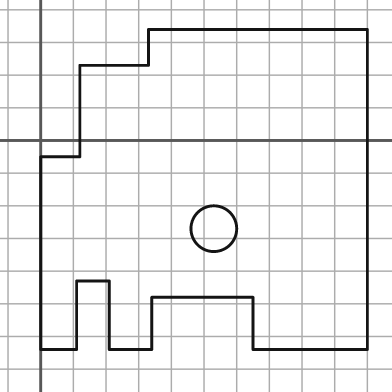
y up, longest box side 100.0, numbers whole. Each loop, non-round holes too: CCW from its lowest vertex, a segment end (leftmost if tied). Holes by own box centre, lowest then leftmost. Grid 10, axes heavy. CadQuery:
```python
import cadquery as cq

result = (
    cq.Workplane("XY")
    .moveTo(0.0, -64.0)
    .lineTo(11.0, -64.0)
    .lineTo(11.0, -43.0)
    .lineTo(21.0, -43.0)
    .lineTo(21.0, -64.0)
    .lineTo(34.0, -64.0)
    .lineTo(34.0, -48.0)
    .lineTo(65.0, -48.0)
    .lineTo(65.0, -64.0)
    .lineTo(100.0, -64.0)
    .lineTo(100.0, 34.0)
    .lineTo(33.0, 34.0)
    .lineTo(33.0, 23.0)
    .lineTo(12.0, 23.0)
    .lineTo(12.0, -5.0)
    .lineTo(0.0, -5.0)
    .close()
    .moveTo(53.0, -27.0)
    .circle(7.0)
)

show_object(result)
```